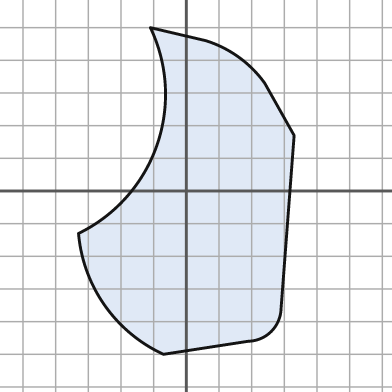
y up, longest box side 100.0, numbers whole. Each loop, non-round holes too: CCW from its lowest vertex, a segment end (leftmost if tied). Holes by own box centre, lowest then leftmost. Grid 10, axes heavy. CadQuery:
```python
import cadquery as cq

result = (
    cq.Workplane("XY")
    .moveTo(-7.0, -50.0)
    .lineTo(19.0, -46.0)
    .threePointArc((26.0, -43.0), (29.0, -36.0))
    .lineTo(33.0, 17.0)
    .lineTo(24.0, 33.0)
    .threePointArc((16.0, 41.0), (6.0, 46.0))
    .lineTo(-11.0, 50.0)
    .threePointArc((-9.0, 14.0), (-33.0, -13.0))
    .threePointArc((-25.0, -35.0), (-7.0, -50.0))
    .close()
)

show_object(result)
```